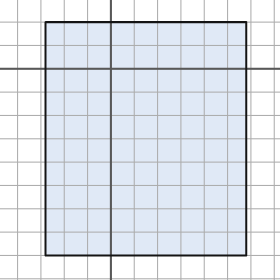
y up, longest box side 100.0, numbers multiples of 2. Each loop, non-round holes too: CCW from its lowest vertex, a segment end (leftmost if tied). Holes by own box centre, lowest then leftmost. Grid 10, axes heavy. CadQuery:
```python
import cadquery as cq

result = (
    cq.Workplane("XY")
    .moveTo(-28.0, -80.0)
    .lineTo(58.0, -80.0)
    .lineTo(58.0, 20.0)
    .lineTo(-28.0, 20.0)
    .close()
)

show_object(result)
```